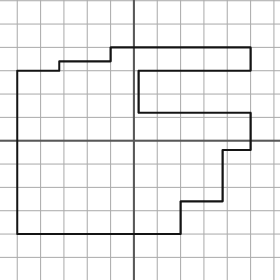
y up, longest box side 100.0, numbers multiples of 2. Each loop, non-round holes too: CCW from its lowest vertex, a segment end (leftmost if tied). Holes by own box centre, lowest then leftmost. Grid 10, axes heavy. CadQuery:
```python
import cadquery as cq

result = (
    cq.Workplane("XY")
    .moveTo(-50.0, -40.0)
    .lineTo(20.0, -40.0)
    .lineTo(20.0, -26.0)
    .lineTo(38.0, -26.0)
    .lineTo(38.0, -4.0)
    .lineTo(50.0, -4.0)
    .lineTo(50.0, 12.0)
    .lineTo(2.0, 12.0)
    .lineTo(2.0, 30.0)
    .lineTo(50.0, 30.0)
    .lineTo(50.0, 40.0)
    .lineTo(-10.0, 40.0)
    .lineTo(-10.0, 34.0)
    .lineTo(-32.0, 34.0)
    .lineTo(-32.0, 30.0)
    .lineTo(-50.0, 30.0)
    .close()
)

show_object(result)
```